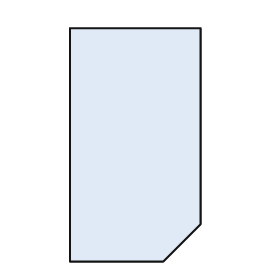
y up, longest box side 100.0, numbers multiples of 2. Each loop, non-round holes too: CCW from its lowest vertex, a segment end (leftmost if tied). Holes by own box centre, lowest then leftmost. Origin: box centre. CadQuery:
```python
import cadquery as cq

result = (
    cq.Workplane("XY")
    .moveTo(-28.0, -50.0)
    .lineTo(12.0, -50.0)
    .lineTo(28.0, -34.0)
    .lineTo(28.0, 50.0)
    .lineTo(-28.0, 50.0)
    .close()
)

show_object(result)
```